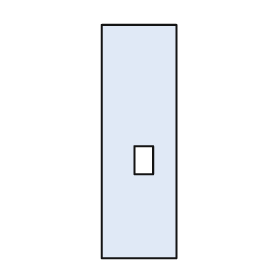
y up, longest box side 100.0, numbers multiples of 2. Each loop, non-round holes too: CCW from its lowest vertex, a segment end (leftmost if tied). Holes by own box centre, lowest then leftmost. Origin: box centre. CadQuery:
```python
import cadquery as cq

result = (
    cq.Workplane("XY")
    .moveTo(-16.0, -50.0)
    .lineTo(16.0, -50.0)
    .lineTo(16.0, 50.0)
    .lineTo(-16.0, 50.0)
    .close()
    .moveTo(-2.0, -14.0)
    .lineTo(6.0, -14.0)
    .lineTo(6.0, -2.0)
    .lineTo(-2.0, -2.0)
    .close()
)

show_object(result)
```